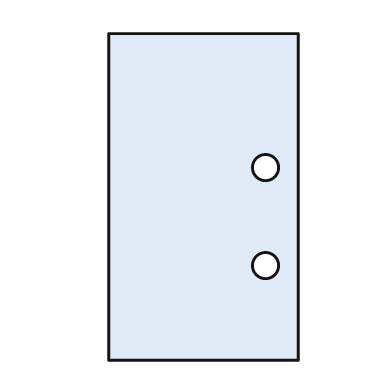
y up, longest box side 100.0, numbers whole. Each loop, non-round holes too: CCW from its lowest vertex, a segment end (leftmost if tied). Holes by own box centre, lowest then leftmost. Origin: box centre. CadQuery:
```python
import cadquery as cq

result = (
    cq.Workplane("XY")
    .moveTo(-29.0, -50.0)
    .lineTo(29.0, -50.0)
    .lineTo(29.0, 50.0)
    .lineTo(-29.0, 50.0)
    .close()
    .moveTo(19.0, -21.0)
    .circle(4.0)
    .moveTo(19.0, 9.0)
    .circle(4.0)
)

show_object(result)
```